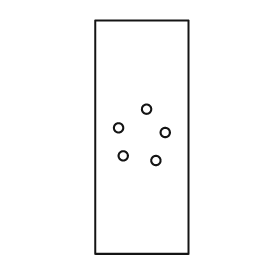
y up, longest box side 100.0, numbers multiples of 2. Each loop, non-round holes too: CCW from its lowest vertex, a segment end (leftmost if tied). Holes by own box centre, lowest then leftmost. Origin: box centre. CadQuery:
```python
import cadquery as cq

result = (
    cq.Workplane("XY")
    .moveTo(-20.0, -50.0)
    .lineTo(20.0, -50.0)
    .lineTo(20.0, 50.0)
    .lineTo(-20.0, 50.0)
    .close()
    .moveTo(6.0, -10.0)
    .circle(2.0)
    .moveTo(-8.0, -8.0)
    .circle(2.0)
    .moveTo(10.0, 2.0)
    .circle(2.0)
    .moveTo(-10.0, 4.0)
    .circle(2.0)
    .moveTo(2.0, 12.0)
    .circle(2.0)
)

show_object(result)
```